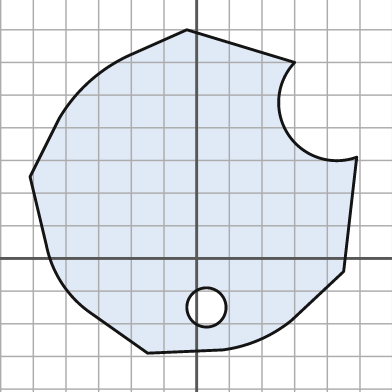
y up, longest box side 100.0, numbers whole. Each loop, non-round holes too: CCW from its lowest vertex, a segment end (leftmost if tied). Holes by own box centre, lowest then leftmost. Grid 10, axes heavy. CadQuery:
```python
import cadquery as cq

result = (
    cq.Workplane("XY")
    .moveTo(-15.0, -29.0)
    .lineTo(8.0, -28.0)
    .threePointArc((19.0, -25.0), (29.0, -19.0))
    .lineTo(45.0, -4.0)
    .lineTo(49.0, 31.0)
    .threePointArc((28.0, 38.0), (30.0, 60.0))
    .lineTo(-3.0, 70.0)
    .lineTo(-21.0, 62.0)
    .threePointArc((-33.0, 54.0), (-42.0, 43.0))
    .lineTo(-51.0, 25.0)
    .lineTo(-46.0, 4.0)
    .threePointArc((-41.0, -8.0), (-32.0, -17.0))
    .close()
    .moveTo(3.0, -15.0)
    .circle(6.0)
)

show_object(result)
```